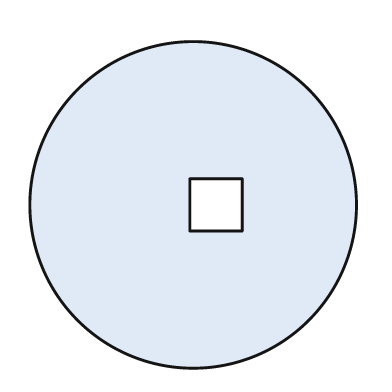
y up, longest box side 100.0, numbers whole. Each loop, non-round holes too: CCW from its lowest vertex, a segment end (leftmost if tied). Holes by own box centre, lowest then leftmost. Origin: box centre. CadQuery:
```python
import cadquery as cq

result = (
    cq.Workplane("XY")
    .moveTo(0.0, 0.0)
    .circle(50.0)
    .moveTo(-1.0, -8.0)
    .lineTo(15.0, -8.0)
    .lineTo(15.0, 8.0)
    .lineTo(-1.0, 8.0)
    .close()
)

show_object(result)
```